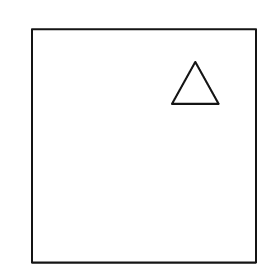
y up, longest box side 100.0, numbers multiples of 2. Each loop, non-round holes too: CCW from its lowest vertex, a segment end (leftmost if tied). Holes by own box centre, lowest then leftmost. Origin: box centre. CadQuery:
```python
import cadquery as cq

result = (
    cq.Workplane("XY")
    .moveTo(-48.0, -50.0)
    .lineTo(48.0, -50.0)
    .lineTo(48.0, 50.0)
    .lineTo(-48.0, 50.0)
    .close()
    .moveTo(12.0, 18.0)
    .lineTo(32.0, 18.0)
    .lineTo(22.0, 36.0)
    .close()
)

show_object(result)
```